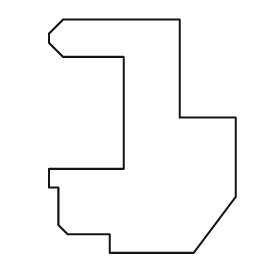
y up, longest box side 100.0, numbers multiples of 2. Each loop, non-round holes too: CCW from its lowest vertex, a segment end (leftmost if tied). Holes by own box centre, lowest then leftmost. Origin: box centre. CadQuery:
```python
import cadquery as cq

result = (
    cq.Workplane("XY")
    .moveTo(-14.0, -50.0)
    .lineTo(22.0, -50.0)
    .lineTo(40.0, -26.0)
    .lineTo(40.0, 8.0)
    .lineTo(16.0, 8.0)
    .lineTo(16.0, 50.0)
    .lineTo(-34.0, 50.0)
    .lineTo(-40.0, 44.0)
    .lineTo(-40.0, 40.0)
    .lineTo(-34.0, 34.0)
    .lineTo(-8.0, 34.0)
    .lineTo(-8.0, -14.0)
    .lineTo(-40.0, -14.0)
    .lineTo(-40.0, -22.0)
    .lineTo(-36.0, -22.0)
    .lineTo(-36.0, -38.0)
    .lineTo(-32.0, -42.0)
    .lineTo(-14.0, -42.0)
    .close()
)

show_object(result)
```